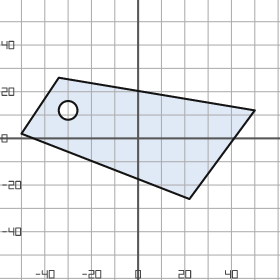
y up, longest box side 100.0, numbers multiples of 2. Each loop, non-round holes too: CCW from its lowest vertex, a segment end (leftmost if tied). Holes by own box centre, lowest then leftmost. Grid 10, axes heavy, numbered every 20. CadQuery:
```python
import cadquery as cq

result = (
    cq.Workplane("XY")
    .moveTo(22.0, -26.0)
    .lineTo(50.0, 12.0)
    .lineTo(-34.0, 26.0)
    .lineTo(-50.0, 2.0)
    .close()
    .moveTo(-30.0, 12.0)
    .circle(4.0)
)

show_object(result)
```